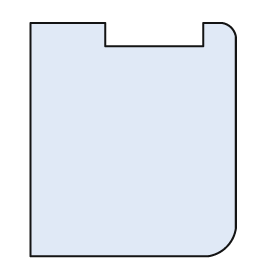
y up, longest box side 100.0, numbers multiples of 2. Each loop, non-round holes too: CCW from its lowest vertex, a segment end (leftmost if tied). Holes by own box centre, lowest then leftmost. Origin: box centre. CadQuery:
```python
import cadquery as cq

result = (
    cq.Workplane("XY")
    .moveTo(-44.0, -50.0)
    .lineTo(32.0, -50.0)
    .threePointArc((40.0, -46.0), (44.0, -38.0))
    .lineTo(44.0, 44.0)
    .threePointArc((42.0, 48.0), (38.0, 50.0))
    .lineTo(30.0, 50.0)
    .lineTo(30.0, 40.0)
    .lineTo(-12.0, 40.0)
    .lineTo(-12.0, 50.0)
    .lineTo(-44.0, 50.0)
    .close()
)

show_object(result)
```